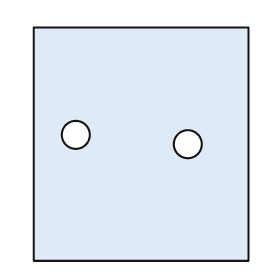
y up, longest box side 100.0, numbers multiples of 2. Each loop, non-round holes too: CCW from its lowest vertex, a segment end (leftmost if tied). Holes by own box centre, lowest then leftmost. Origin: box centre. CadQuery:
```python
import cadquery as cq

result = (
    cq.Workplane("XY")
    .moveTo(-46.0, -50.0)
    .lineTo(46.0, -50.0)
    .lineTo(46.0, 50.0)
    .lineTo(-46.0, 50.0)
    .close()
    .moveTo(20.0, 0.0)
    .circle(6.0)
    .moveTo(-28.0, 4.0)
    .circle(6.0)
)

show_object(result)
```